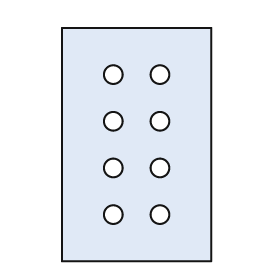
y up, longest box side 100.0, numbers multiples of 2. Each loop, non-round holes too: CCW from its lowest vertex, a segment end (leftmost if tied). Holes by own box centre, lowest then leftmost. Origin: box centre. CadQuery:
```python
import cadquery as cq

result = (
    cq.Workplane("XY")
    .moveTo(-32.0, -50.0)
    .lineTo(32.0, -50.0)
    .lineTo(32.0, 50.0)
    .lineTo(-32.0, 50.0)
    .close()
    .moveTo(-10.0, -30.0)
    .circle(4.0)
    .moveTo(10.0, -30.0)
    .circle(4.0)
    .moveTo(-10.0, -10.0)
    .circle(4.0)
    .moveTo(10.0, -10.0)
    .circle(4.0)
    .moveTo(-10.0, 10.0)
    .circle(4.0)
    .moveTo(10.0, 10.0)
    .circle(4.0)
    .moveTo(-10.0, 30.0)
    .circle(4.0)
    .moveTo(10.0, 30.0)
    .circle(4.0)
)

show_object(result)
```